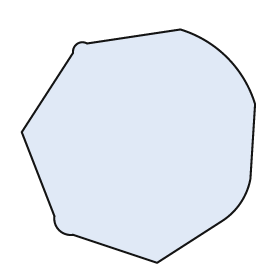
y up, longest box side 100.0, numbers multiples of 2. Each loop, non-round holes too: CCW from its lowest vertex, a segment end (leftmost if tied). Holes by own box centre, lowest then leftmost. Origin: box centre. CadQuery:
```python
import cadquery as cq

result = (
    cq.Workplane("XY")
    .moveTo(8.0, -50.0)
    .lineTo(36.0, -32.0)
    .threePointArc((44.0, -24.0), (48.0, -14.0))
    .lineTo(50.0, 18.0)
    .threePointArc((38.0, 38.0), (18.0, 50.0))
    .lineTo(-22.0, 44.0)
    .threePointArc((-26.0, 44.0), (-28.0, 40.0))
    .lineTo(-50.0, 6.0)
    .lineTo(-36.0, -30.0)
    .threePointArc((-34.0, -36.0), (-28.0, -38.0))
    .close()
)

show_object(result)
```